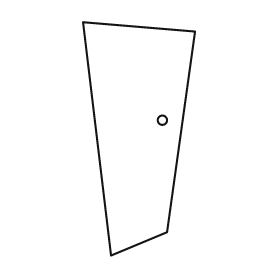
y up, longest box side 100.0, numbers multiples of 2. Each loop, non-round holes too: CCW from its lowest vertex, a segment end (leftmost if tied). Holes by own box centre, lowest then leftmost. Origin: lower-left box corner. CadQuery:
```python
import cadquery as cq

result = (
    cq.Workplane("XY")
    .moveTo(12.0, 0.0)
    .lineTo(36.0, 10.0)
    .lineTo(48.0, 96.0)
    .lineTo(0.0, 100.0)
    .close()
    .moveTo(34.0, 58.0)
    .circle(2.0)
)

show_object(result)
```